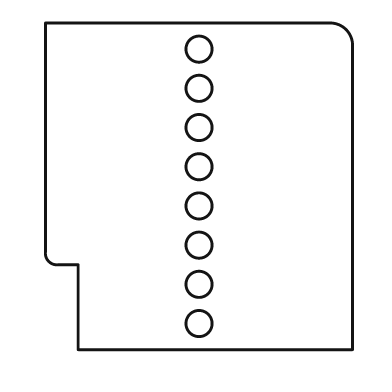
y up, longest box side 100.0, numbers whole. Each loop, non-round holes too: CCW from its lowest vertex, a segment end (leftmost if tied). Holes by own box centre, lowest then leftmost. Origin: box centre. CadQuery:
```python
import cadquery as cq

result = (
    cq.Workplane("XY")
    .moveTo(-37.0, -50.0)
    .lineTo(47.0, -50.0)
    .lineTo(47.0, 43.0)
    .threePointArc((45.0, 48.0), (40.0, 50.0))
    .lineTo(-47.0, 50.0)
    .lineTo(-47.0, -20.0)
    .threePointArc((-46.0, -23.0), (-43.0, -24.0))
    .lineTo(-37.0, -24.0)
    .close()
    .moveTo(0.0, -42.0)
    .circle(4.0)
    .moveTo(0.0, -30.0)
    .circle(4.0)
    .moveTo(0.0, -18.0)
    .circle(4.0)
    .moveTo(0.0, -6.0)
    .circle(4.0)
    .moveTo(0.0, 6.0)
    .circle(4.0)
    .moveTo(0.0, 18.0)
    .circle(4.0)
    .moveTo(0.0, 30.0)
    .circle(4.0)
    .moveTo(0.0, 42.0)
    .circle(4.0)
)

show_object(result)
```